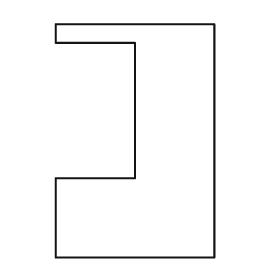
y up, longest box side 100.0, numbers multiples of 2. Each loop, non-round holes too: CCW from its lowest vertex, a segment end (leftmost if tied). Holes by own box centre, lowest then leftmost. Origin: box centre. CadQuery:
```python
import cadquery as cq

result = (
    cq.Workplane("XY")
    .moveTo(-34.0, -50.0)
    .lineTo(34.0, -50.0)
    .lineTo(34.0, 50.0)
    .lineTo(-34.0, 50.0)
    .lineTo(-34.0, 42.0)
    .lineTo(0.0, 42.0)
    .lineTo(0.0, -16.0)
    .lineTo(-34.0, -16.0)
    .close()
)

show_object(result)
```